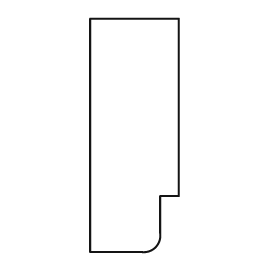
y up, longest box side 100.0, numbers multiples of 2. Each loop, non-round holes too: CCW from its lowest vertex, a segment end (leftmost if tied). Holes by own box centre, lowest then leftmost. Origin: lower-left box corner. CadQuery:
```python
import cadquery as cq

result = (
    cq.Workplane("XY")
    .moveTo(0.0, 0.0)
    .lineTo(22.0, 0.0)
    .threePointArc((28.0, 2.0), (30.0, 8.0))
    .lineTo(30.0, 24.0)
    .lineTo(38.0, 24.0)
    .lineTo(38.0, 100.0)
    .lineTo(0.0, 100.0)
    .close()
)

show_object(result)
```